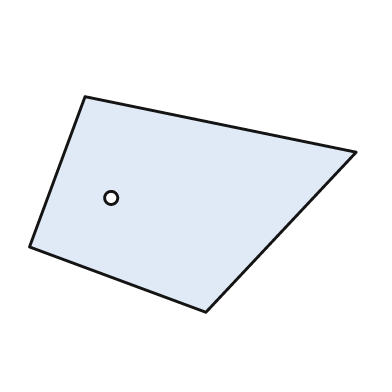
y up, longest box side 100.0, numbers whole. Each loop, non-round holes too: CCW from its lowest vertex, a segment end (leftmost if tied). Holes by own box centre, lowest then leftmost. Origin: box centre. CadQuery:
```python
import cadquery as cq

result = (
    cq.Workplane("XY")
    .moveTo(4.0, -33.0)
    .lineTo(50.0, 16.0)
    .lineTo(-33.0, 33.0)
    .lineTo(-50.0, -13.0)
    .close()
    .moveTo(-25.0, 2.0)
    .circle(2.0)
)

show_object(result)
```